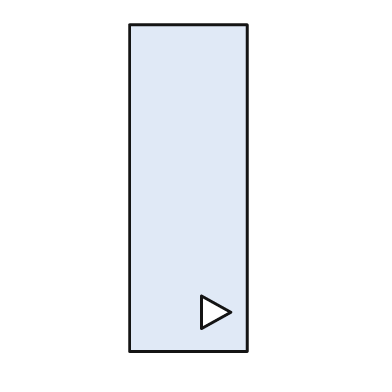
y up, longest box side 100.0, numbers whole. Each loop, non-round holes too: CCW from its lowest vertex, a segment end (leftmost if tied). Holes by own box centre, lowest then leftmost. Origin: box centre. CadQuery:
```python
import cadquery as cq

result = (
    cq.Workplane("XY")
    .moveTo(-18.0, -50.0)
    .lineTo(18.0, -50.0)
    .lineTo(18.0, 50.0)
    .lineTo(-18.0, 50.0)
    .close()
    .moveTo(4.0, -43.0)
    .lineTo(13.0, -38.0)
    .lineTo(4.0, -33.0)
    .close()
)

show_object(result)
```